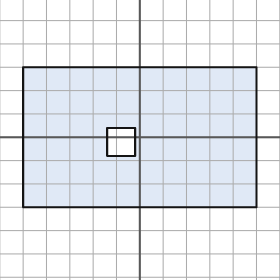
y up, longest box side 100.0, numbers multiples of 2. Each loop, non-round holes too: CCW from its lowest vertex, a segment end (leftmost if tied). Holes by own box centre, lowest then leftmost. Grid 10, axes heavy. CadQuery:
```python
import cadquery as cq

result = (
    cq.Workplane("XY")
    .moveTo(-50.0, -30.0)
    .lineTo(50.0, -30.0)
    .lineTo(50.0, 30.0)
    .lineTo(-50.0, 30.0)
    .close()
    .moveTo(-14.0, -8.0)
    .lineTo(-2.0, -8.0)
    .lineTo(-2.0, 4.0)
    .lineTo(-14.0, 4.0)
    .close()
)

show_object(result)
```